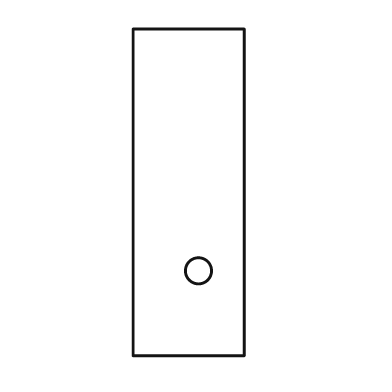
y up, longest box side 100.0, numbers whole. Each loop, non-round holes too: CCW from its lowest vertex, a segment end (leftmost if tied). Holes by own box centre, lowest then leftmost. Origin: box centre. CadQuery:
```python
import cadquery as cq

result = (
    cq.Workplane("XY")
    .moveTo(-17.0, -50.0)
    .lineTo(17.0, -50.0)
    .lineTo(17.0, 50.0)
    .lineTo(-17.0, 50.0)
    .close()
    .moveTo(3.0, -24.0)
    .circle(4.0)
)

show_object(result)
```